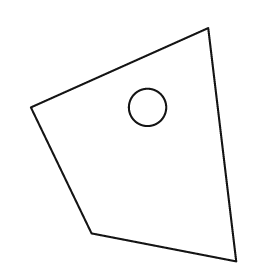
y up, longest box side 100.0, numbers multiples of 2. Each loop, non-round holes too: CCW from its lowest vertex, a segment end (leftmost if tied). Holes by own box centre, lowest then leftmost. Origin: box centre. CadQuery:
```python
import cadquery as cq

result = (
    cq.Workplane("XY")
    .moveTo(44.0, -50.0)
    .lineTo(32.0, 50.0)
    .lineTo(-44.0, 16.0)
    .lineTo(-18.0, -38.0)
    .close()
    .moveTo(6.0, 16.0)
    .circle(8.0)
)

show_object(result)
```